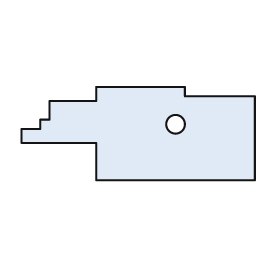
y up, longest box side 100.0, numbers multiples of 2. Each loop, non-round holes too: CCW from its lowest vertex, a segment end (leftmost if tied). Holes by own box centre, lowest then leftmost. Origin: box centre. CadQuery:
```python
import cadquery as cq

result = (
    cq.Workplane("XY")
    .moveTo(-18.0, -20.0)
    .lineTo(50.0, -20.0)
    .lineTo(50.0, 16.0)
    .lineTo(20.0, 16.0)
    .lineTo(20.0, 20.0)
    .lineTo(-18.0, 20.0)
    .lineTo(-18.0, 14.0)
    .lineTo(-38.0, 14.0)
    .lineTo(-38.0, 6.0)
    .lineTo(-42.0, 6.0)
    .lineTo(-42.0, 2.0)
    .lineTo(-50.0, 2.0)
    .lineTo(-50.0, -4.0)
    .lineTo(-18.0, -4.0)
    .close()
    .moveTo(16.0, 4.0)
    .circle(4.0)
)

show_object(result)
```